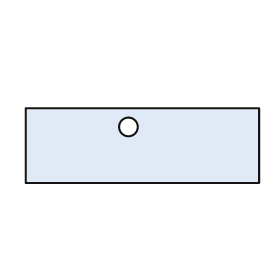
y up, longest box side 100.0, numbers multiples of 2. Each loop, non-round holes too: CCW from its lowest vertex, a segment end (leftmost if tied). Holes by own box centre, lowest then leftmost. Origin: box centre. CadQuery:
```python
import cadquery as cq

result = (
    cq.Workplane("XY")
    .moveTo(-50.0, -16.0)
    .lineTo(50.0, -16.0)
    .lineTo(50.0, 16.0)
    .lineTo(-50.0, 16.0)
    .close()
    .moveTo(-6.0, 8.0)
    .circle(4.0)
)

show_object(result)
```